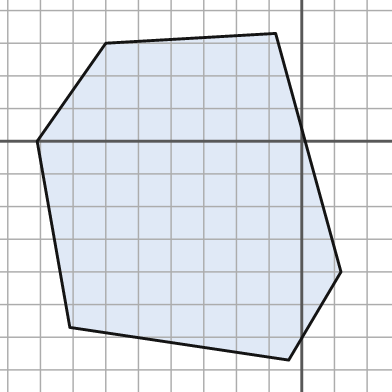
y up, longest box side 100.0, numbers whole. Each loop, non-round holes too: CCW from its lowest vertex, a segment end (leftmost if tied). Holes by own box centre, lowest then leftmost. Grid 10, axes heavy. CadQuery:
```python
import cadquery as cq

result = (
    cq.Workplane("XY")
    .moveTo(-4.0, -67.0)
    .lineTo(12.0, -40.0)
    .lineTo(-8.0, 33.0)
    .lineTo(-60.0, 30.0)
    .lineTo(-81.0, 0.0)
    .lineTo(-71.0, -57.0)
    .close()
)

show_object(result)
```